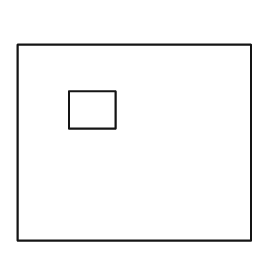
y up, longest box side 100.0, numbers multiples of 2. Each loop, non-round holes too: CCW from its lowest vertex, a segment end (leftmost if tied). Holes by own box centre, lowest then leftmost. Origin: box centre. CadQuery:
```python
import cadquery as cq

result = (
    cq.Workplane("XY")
    .moveTo(-50.0, -42.0)
    .lineTo(50.0, -42.0)
    .lineTo(50.0, 42.0)
    .lineTo(-50.0, 42.0)
    .close()
    .moveTo(-28.0, 6.0)
    .lineTo(-8.0, 6.0)
    .lineTo(-8.0, 22.0)
    .lineTo(-28.0, 22.0)
    .close()
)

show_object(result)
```